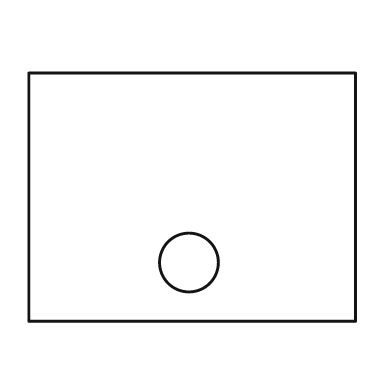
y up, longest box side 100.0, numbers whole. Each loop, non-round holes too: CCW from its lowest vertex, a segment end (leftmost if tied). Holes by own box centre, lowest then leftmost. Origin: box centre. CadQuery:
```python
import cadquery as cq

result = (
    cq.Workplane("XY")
    .moveTo(-50.0, -38.0)
    .lineTo(50.0, -38.0)
    .lineTo(50.0, 38.0)
    .lineTo(-50.0, 38.0)
    .close()
    .moveTo(-1.0, -20.0)
    .circle(9.0)
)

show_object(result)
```